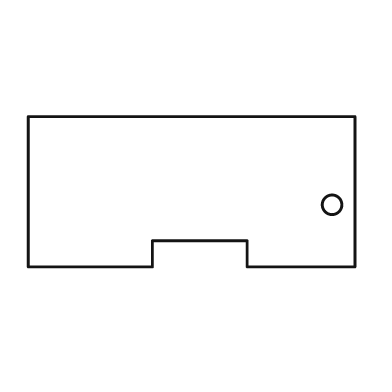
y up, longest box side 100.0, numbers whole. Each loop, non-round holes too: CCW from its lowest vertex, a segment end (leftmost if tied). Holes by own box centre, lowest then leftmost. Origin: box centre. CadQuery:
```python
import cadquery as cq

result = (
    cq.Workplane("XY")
    .moveTo(-50.0, -23.0)
    .lineTo(-12.0, -23.0)
    .lineTo(-12.0, -15.0)
    .lineTo(17.0, -15.0)
    .lineTo(17.0, -23.0)
    .lineTo(50.0, -23.0)
    .lineTo(50.0, 23.0)
    .lineTo(-50.0, 23.0)
    .close()
    .moveTo(43.0, -4.0)
    .circle(3.0)
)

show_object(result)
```